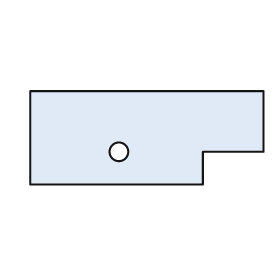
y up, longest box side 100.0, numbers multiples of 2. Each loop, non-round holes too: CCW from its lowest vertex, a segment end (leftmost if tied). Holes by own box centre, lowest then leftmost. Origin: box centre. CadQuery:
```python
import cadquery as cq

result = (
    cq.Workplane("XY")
    .moveTo(-50.0, -20.0)
    .lineTo(24.0, -20.0)
    .lineTo(24.0, -6.0)
    .lineTo(50.0, -6.0)
    .lineTo(50.0, 20.0)
    .lineTo(-50.0, 20.0)
    .close()
    .moveTo(-12.0, -6.0)
    .circle(4.0)
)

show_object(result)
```